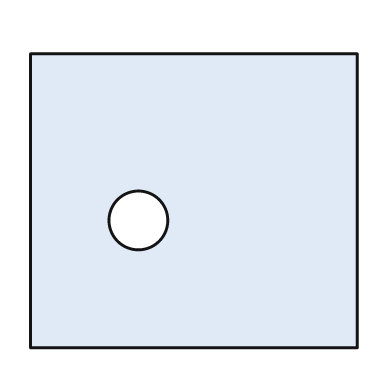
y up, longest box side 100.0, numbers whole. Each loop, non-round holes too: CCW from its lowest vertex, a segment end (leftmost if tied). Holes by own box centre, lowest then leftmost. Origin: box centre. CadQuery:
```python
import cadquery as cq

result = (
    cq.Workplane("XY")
    .moveTo(-50.0, -45.0)
    .lineTo(50.0, -45.0)
    .lineTo(50.0, 45.0)
    .lineTo(-50.0, 45.0)
    .close()
    .moveTo(-17.0, -6.0)
    .circle(9.0)
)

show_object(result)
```